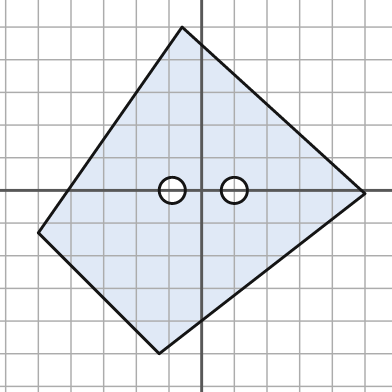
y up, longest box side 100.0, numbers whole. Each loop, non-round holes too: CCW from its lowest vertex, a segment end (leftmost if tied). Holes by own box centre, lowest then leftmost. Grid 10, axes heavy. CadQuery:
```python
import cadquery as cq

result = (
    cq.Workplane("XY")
    .moveTo(-13.0, -50.0)
    .lineTo(50.0, -1.0)
    .lineTo(-6.0, 50.0)
    .lineTo(-50.0, -13.0)
    .close()
    .moveTo(-9.0, 0.0)
    .circle(4.0)
    .moveTo(10.0, 0.0)
    .circle(4.0)
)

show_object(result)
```